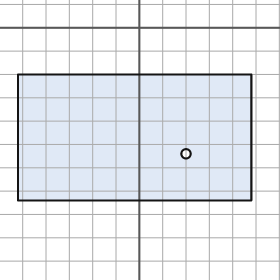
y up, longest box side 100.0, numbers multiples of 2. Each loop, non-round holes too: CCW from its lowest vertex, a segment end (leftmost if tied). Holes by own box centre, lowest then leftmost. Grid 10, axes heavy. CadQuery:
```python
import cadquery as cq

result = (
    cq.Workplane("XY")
    .moveTo(-52.0, -74.0)
    .lineTo(48.0, -74.0)
    .lineTo(48.0, -20.0)
    .lineTo(-52.0, -20.0)
    .close()
    .moveTo(20.0, -54.0)
    .circle(2.0)
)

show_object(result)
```